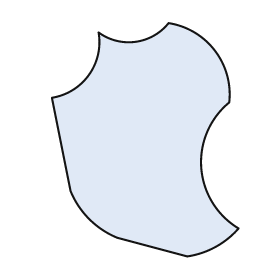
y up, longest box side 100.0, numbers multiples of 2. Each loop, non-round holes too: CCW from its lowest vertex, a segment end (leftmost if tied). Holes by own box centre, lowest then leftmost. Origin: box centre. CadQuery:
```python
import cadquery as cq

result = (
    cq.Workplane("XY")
    .moveTo(18.0, -50.0)
    .threePointArc((30.0, -46.0), (40.0, -38.0))
    .threePointArc((24.0, -12.0), (36.0, 16.0))
    .threePointArc((30.0, 38.0), (10.0, 50.0))
    .threePointArc((-4.0, 42.0), (-20.0, 46.0))
    .threePointArc((-24.0, 28.0), (-40.0, 18.0))
    .lineTo(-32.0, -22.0)
    .threePointArc((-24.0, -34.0), (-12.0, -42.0))
    .close()
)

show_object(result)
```